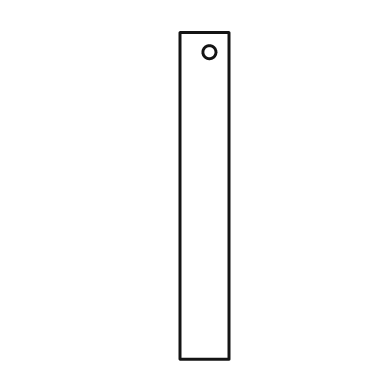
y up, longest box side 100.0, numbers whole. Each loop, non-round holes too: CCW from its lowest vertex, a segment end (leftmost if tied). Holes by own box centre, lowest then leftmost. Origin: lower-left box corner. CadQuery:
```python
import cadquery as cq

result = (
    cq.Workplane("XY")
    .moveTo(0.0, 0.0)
    .lineTo(15.0, 0.0)
    .lineTo(15.0, 100.0)
    .lineTo(0.0, 100.0)
    .close()
    .moveTo(9.0, 94.0)
    .circle(2.0)
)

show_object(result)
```